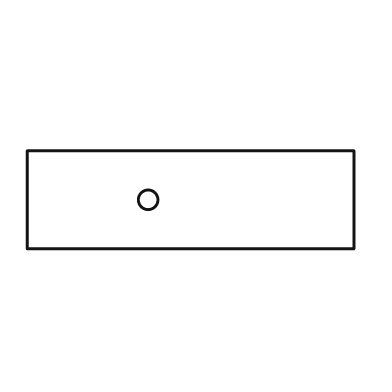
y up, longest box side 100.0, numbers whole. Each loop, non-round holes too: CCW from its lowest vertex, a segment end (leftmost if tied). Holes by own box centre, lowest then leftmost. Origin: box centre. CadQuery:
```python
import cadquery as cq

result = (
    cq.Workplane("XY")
    .moveTo(-50.0, -15.0)
    .lineTo(50.0, -15.0)
    .lineTo(50.0, 15.0)
    .lineTo(-50.0, 15.0)
    .close()
    .moveTo(-13.0, 0.0)
    .circle(3.0)
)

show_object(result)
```